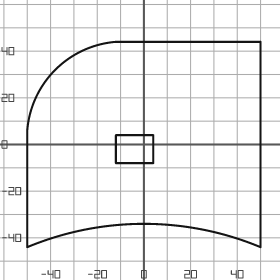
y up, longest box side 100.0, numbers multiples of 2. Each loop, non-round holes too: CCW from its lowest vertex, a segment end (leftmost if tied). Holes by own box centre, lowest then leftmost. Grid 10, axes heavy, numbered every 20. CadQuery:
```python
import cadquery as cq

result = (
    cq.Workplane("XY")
    .moveTo(-50.0, -44.0)
    .threePointArc((0.0, -34.0), (50.0, -44.0))
    .lineTo(50.0, 44.0)
    .lineTo(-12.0, 44.0)
    .threePointArc((-38.0, 32.0), (-50.0, 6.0))
    .close()
    .moveTo(-12.0, -8.0)
    .lineTo(4.0, -8.0)
    .lineTo(4.0, 4.0)
    .lineTo(-12.0, 4.0)
    .close()
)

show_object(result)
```